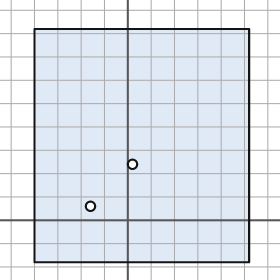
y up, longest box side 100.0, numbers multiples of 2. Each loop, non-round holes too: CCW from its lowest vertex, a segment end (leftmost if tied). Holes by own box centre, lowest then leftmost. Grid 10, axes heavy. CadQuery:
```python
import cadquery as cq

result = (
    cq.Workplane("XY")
    .moveTo(-40.0, -18.0)
    .lineTo(52.0, -18.0)
    .lineTo(52.0, 82.0)
    .lineTo(-40.0, 82.0)
    .close()
    .moveTo(-16.0, 6.0)
    .circle(2.0)
    .moveTo(2.0, 24.0)
    .circle(2.0)
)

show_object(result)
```